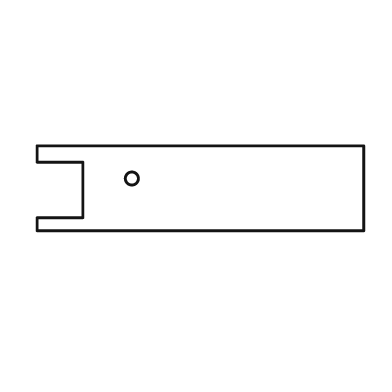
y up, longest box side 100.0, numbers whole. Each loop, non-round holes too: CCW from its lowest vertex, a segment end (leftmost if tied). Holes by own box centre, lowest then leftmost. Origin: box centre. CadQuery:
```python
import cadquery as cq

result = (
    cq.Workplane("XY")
    .moveTo(-50.0, -13.0)
    .lineTo(50.0, -13.0)
    .lineTo(50.0, 13.0)
    .lineTo(-50.0, 13.0)
    .lineTo(-50.0, 8.0)
    .lineTo(-36.0, 8.0)
    .lineTo(-36.0, -9.0)
    .lineTo(-50.0, -9.0)
    .close()
    .moveTo(-21.0, 3.0)
    .circle(2.0)
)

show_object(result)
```